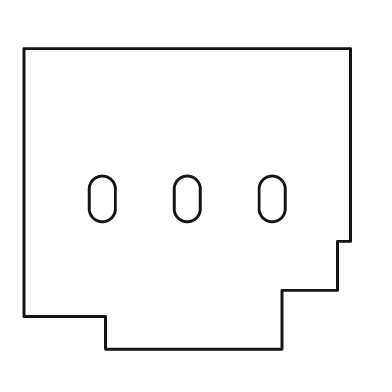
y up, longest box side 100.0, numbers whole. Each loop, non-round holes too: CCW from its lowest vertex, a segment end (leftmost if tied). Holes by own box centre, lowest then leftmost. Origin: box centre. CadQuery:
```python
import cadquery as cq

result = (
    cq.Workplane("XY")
    .moveTo(-25.0, -46.0)
    .lineTo(29.0, -46.0)
    .lineTo(29.0, -28.0)
    .lineTo(46.0, -28.0)
    .lineTo(46.0, -13.0)
    .lineTo(50.0, -13.0)
    .lineTo(50.0, 46.0)
    .lineTo(-50.0, 46.0)
    .lineTo(-50.0, -36.0)
    .lineTo(-25.0, -36.0)
    .close()
    .moveTo(-30.0, -3.0)
    .threePointArc((-26.0, -7.0), (-22.0, -3.0))
    .lineTo(-22.0, 3.0)
    .threePointArc((-26.0, 7.0), (-30.0, 3.0))
    .close()
    .moveTo(-4.0, -3.0)
    .threePointArc((0.0, -7.0), (4.0, -3.0))
    .lineTo(4.0, 3.0)
    .threePointArc((0.0, 7.0), (-4.0, 3.0))
    .close()
    .moveTo(22.0, -3.0)
    .threePointArc((26.0, -7.0), (30.0, -3.0))
    .lineTo(30.0, 3.0)
    .threePointArc((26.0, 7.0), (22.0, 3.0))
    .close()
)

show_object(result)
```